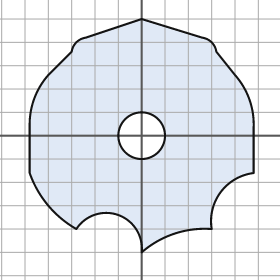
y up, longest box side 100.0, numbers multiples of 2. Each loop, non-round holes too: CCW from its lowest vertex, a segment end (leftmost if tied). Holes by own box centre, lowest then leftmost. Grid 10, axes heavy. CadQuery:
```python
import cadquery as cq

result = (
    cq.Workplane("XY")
    .moveTo(0.0, -50.0)
    .threePointArc((14.0, -42.0), (30.0, -40.0))
    .threePointArc((34.0, -24.0), (48.0, -16.0))
    .lineTo(48.0, 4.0)
    .threePointArc((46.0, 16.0), (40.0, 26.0))
    .lineTo(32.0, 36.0)
    .threePointArc((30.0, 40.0), (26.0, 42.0))
    .lineTo(0.0, 50.0)
    .lineTo(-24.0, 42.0)
    .threePointArc((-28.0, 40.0), (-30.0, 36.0))
    .lineTo(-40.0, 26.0)
    .threePointArc((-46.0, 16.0), (-48.0, 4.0))
    .lineTo(-48.0, -16.0)
    .threePointArc((-40.0, -30.0), (-28.0, -40.0))
    .threePointArc((-10.0, -34.0), (0.0, -50.0))
    .close()
    .moveTo(0.0, 0.0)
    .circle(10.0)
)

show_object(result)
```